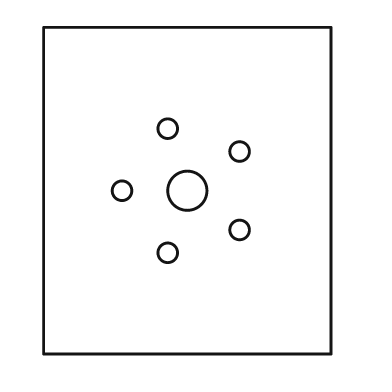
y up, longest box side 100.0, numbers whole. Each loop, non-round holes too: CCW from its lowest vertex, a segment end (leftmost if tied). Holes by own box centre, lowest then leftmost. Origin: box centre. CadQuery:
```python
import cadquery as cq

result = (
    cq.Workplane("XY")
    .moveTo(-44.0, -50.0)
    .lineTo(44.0, -50.0)
    .lineTo(44.0, 50.0)
    .lineTo(-44.0, 50.0)
    .close()
    .moveTo(-6.0, -19.0)
    .circle(3.0)
    .moveTo(16.0, -12.0)
    .circle(3.0)
    .moveTo(-20.0, 0.0)
    .circle(3.0)
    .moveTo(0.0, 0.0)
    .circle(6.0)
    .moveTo(16.0, 12.0)
    .circle(3.0)
    .moveTo(-6.0, 19.0)
    .circle(3.0)
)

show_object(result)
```